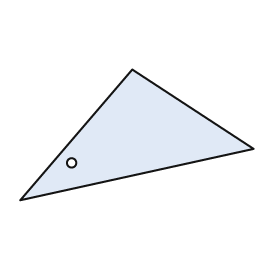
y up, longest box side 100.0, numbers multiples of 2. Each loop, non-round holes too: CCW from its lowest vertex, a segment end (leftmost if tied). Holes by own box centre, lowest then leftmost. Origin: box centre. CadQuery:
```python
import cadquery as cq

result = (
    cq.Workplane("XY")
    .moveTo(-50.0, -28.0)
    .lineTo(50.0, -6.0)
    .lineTo(-2.0, 28.0)
    .close()
    .moveTo(-28.0, -12.0)
    .circle(2.0)
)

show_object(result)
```